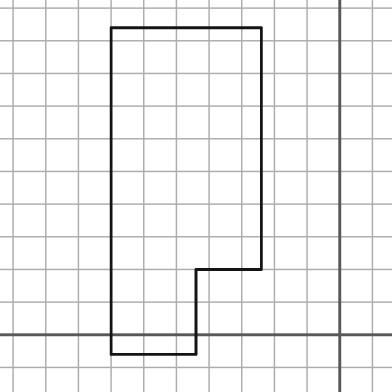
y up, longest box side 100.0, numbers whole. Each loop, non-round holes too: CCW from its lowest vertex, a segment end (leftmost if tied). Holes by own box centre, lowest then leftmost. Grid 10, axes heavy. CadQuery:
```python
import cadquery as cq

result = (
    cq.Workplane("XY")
    .moveTo(-70.0, -6.0)
    .lineTo(-44.0, -6.0)
    .lineTo(-44.0, 20.0)
    .lineTo(-24.0, 20.0)
    .lineTo(-24.0, 94.0)
    .lineTo(-70.0, 94.0)
    .close()
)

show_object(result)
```